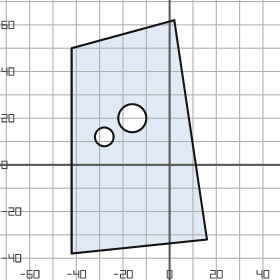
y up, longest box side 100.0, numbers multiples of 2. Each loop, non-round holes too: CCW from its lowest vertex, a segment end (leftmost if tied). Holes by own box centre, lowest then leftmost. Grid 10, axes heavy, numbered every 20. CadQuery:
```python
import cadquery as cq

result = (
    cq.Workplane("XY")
    .moveTo(-42.0, -38.0)
    .lineTo(16.0, -32.0)
    .lineTo(2.0, 62.0)
    .lineTo(-42.0, 50.0)
    .close()
    .moveTo(-28.0, 12.0)
    .circle(4.0)
    .moveTo(-16.0, 20.0)
    .circle(6.0)
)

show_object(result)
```